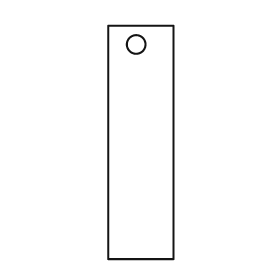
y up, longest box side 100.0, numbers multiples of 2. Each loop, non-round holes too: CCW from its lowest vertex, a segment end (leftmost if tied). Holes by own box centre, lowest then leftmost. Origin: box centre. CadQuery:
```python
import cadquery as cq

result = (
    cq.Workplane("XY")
    .moveTo(-14.0, -50.0)
    .lineTo(14.0, -50.0)
    .lineTo(14.0, 50.0)
    .lineTo(-14.0, 50.0)
    .close()
    .moveTo(-2.0, 42.0)
    .circle(4.0)
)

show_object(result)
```